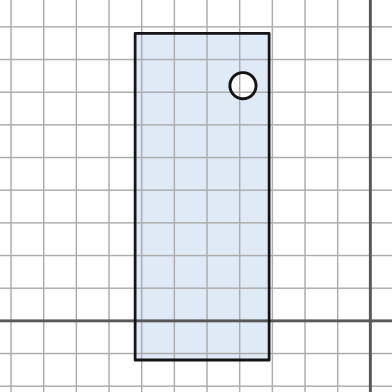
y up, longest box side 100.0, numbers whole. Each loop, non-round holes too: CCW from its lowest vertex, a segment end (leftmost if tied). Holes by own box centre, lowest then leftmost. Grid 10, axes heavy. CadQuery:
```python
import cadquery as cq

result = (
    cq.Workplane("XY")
    .moveTo(-72.0, -12.0)
    .lineTo(-31.0, -12.0)
    .lineTo(-31.0, 88.0)
    .lineTo(-72.0, 88.0)
    .close()
    .moveTo(-39.0, 72.0)
    .circle(4.0)
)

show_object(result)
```